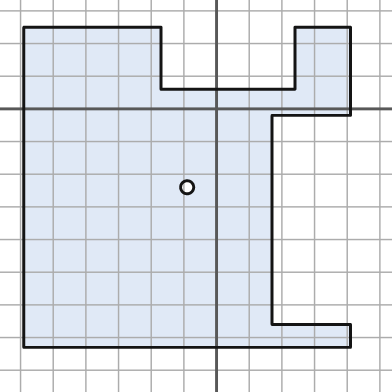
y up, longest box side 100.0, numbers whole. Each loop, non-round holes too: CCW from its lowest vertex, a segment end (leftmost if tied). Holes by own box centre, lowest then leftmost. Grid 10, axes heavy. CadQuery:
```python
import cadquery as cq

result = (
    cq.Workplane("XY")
    .moveTo(-59.0, -73.0)
    .lineTo(41.0, -73.0)
    .lineTo(41.0, -66.0)
    .lineTo(17.0, -66.0)
    .lineTo(17.0, -2.0)
    .lineTo(41.0, -2.0)
    .lineTo(41.0, 25.0)
    .lineTo(24.0, 25.0)
    .lineTo(24.0, 6.0)
    .lineTo(-17.0, 6.0)
    .lineTo(-17.0, 25.0)
    .lineTo(-59.0, 25.0)
    .close()
    .moveTo(-9.0, -24.0)
    .circle(2.0)
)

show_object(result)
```